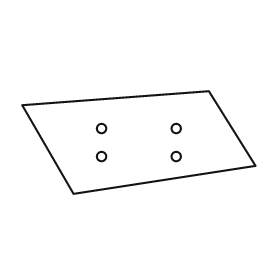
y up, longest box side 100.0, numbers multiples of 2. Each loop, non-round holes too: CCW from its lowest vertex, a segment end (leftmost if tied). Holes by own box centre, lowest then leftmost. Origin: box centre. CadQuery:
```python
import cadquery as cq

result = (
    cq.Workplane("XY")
    .moveTo(-28.0, -22.0)
    .lineTo(50.0, -10.0)
    .lineTo(30.0, 22.0)
    .lineTo(-50.0, 16.0)
    .close()
    .moveTo(-16.0, -6.0)
    .circle(2.0)
    .moveTo(16.0, -6.0)
    .circle(2.0)
    .moveTo(-16.0, 6.0)
    .circle(2.0)
    .moveTo(16.0, 6.0)
    .circle(2.0)
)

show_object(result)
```